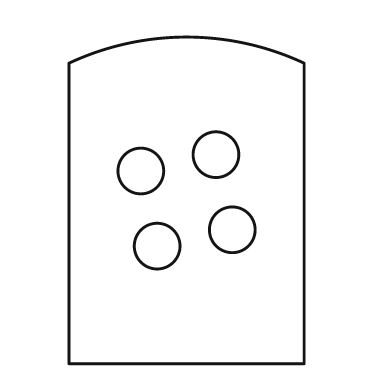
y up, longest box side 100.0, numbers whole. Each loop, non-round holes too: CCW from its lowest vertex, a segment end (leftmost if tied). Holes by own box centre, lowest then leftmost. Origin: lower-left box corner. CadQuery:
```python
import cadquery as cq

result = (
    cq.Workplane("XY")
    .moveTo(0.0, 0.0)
    .lineTo(72.0, 0.0)
    .lineTo(72.0, 92.0)
    .threePointArc((36.0, 100.0), (0.0, 92.0))
    .close()
    .moveTo(27.0, 36.0)
    .circle(7.0)
    .moveTo(50.0, 41.0)
    .circle(7.0)
    .moveTo(22.0, 59.0)
    .circle(7.0)
    .moveTo(45.0, 64.0)
    .circle(7.0)
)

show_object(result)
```